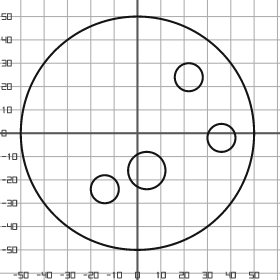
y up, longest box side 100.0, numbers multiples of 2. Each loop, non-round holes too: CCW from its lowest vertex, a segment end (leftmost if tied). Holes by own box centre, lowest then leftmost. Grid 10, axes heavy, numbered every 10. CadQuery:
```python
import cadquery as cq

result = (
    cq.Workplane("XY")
    .moveTo(0.0, 0.0)
    .circle(50.0)
    .moveTo(-14.0, -24.0)
    .circle(6.0)
    .moveTo(4.0, -16.0)
    .circle(8.0)
    .moveTo(36.0, -2.0)
    .circle(6.0)
    .moveTo(22.0, 24.0)
    .circle(6.0)
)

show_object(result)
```